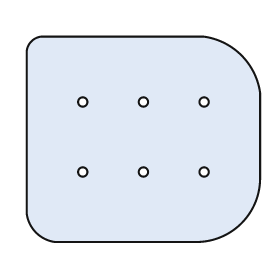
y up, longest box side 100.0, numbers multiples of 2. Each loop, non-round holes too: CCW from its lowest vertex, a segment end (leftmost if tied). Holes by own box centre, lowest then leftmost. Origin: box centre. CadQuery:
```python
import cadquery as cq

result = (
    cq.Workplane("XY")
    .moveTo(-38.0, -44.0)
    .lineTo(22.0, -44.0)
    .threePointArc((42.0, -36.0), (50.0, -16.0))
    .lineTo(50.0, 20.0)
    .threePointArc((42.0, 36.0), (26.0, 44.0))
    .lineTo(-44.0, 44.0)
    .threePointArc((-48.0, 42.0), (-50.0, 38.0))
    .lineTo(-50.0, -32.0)
    .threePointArc((-46.0, -40.0), (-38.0, -44.0))
    .close()
    .moveTo(-26.0, -14.0)
    .circle(2.0)
    .moveTo(0.0, -14.0)
    .circle(2.0)
    .moveTo(26.0, -14.0)
    .circle(2.0)
    .moveTo(-26.0, 16.0)
    .circle(2.0)
    .moveTo(0.0, 16.0)
    .circle(2.0)
    .moveTo(26.0, 16.0)
    .circle(2.0)
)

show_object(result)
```